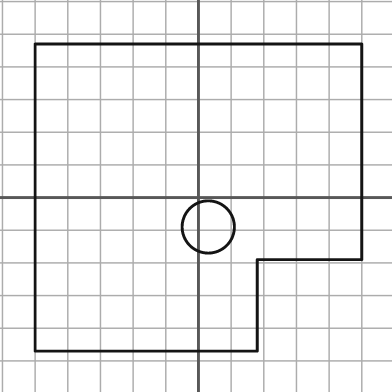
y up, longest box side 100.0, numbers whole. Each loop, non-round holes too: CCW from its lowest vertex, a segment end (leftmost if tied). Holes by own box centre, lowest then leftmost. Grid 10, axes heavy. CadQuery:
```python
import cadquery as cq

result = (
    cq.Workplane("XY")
    .moveTo(-50.0, -47.0)
    .lineTo(18.0, -47.0)
    .lineTo(18.0, -19.0)
    .lineTo(50.0, -19.0)
    .lineTo(50.0, 47.0)
    .lineTo(-50.0, 47.0)
    .close()
    .moveTo(3.0, -9.0)
    .circle(8.0)
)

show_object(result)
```